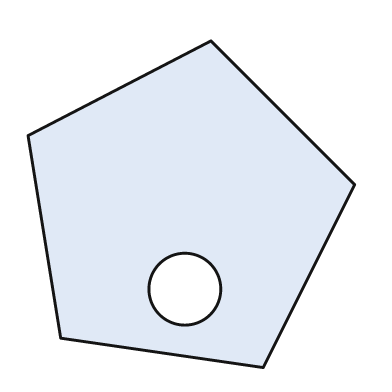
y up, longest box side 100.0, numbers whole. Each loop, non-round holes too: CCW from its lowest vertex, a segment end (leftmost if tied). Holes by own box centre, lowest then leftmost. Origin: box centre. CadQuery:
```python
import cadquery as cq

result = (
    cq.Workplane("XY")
    .moveTo(22.0, -50.0)
    .lineTo(50.0, 6.0)
    .lineTo(6.0, 50.0)
    .lineTo(-50.0, 21.0)
    .lineTo(-40.0, -41.0)
    .close()
    .moveTo(-2.0, -26.0)
    .circle(11.0)
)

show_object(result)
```